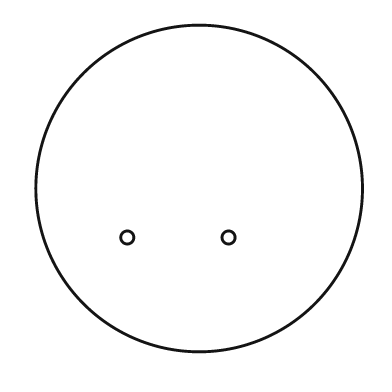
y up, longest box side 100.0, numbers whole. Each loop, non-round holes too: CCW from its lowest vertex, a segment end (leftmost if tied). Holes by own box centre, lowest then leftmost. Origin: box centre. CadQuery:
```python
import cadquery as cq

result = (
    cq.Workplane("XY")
    .moveTo(0.0, 0.0)
    .circle(50.0)
    .moveTo(-22.0, -15.0)
    .circle(2.0)
    .moveTo(9.0, -15.0)
    .circle(2.0)
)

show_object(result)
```